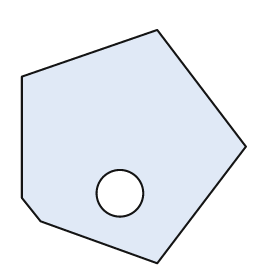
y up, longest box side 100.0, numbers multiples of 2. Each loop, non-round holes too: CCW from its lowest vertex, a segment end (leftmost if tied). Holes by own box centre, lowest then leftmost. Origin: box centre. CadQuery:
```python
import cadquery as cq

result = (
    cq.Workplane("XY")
    .moveTo(10.0, -50.0)
    .lineTo(48.0, 0.0)
    .lineTo(10.0, 50.0)
    .lineTo(-48.0, 30.0)
    .lineTo(-48.0, -22.0)
    .lineTo(-40.0, -32.0)
    .close()
    .moveTo(-6.0, -20.0)
    .circle(10.0)
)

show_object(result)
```